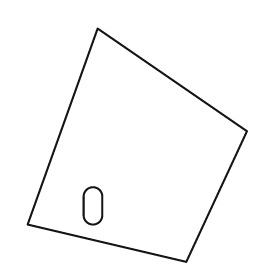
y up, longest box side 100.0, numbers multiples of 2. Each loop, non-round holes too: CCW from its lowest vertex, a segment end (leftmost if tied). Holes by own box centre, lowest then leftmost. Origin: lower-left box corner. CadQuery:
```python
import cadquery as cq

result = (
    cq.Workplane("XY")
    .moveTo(68.0, 0.0)
    .lineTo(94.0, 56.0)
    .lineTo(30.0, 100.0)
    .lineTo(0.0, 16.0)
    .close()
    .moveTo(24.0, 20.0)
    .threePointArc((28.0, 16.0), (32.0, 20.0))
    .lineTo(32.0, 28.0)
    .threePointArc((28.0, 32.0), (24.0, 28.0))
    .close()
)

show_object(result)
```